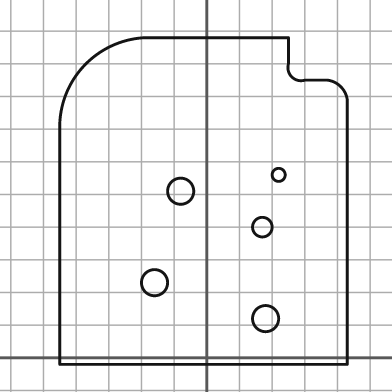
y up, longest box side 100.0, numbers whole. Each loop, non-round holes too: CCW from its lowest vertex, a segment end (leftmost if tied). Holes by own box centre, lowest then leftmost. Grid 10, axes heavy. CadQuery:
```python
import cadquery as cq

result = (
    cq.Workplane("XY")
    .moveTo(-45.0, -2.0)
    .lineTo(43.0, -2.0)
    .lineTo(43.0, 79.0)
    .threePointArc((41.0, 83.0), (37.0, 85.0))
    .lineTo(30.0, 85.0)
    .threePointArc((26.0, 86.0), (25.0, 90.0))
    .lineTo(25.0, 98.0)
    .lineTo(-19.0, 98.0)
    .threePointArc((-37.0, 90.0), (-45.0, 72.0))
    .close()
    .moveTo(18.0, 12.0)
    .circle(4.0)
    .moveTo(-16.0, 23.0)
    .circle(4.0)
    .moveTo(17.0, 40.0)
    .circle(3.0)
    .moveTo(-8.0, 51.0)
    .circle(4.0)
    .moveTo(22.0, 56.0)
    .circle(2.0)
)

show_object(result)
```